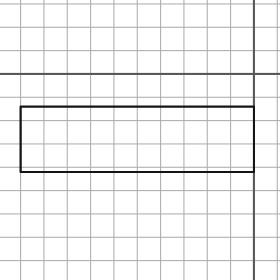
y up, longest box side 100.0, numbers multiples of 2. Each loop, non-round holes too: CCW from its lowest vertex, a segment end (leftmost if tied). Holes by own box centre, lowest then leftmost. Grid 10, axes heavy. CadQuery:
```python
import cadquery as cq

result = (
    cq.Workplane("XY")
    .moveTo(-100.0, -42.0)
    .lineTo(0.0, -42.0)
    .lineTo(0.0, -14.0)
    .lineTo(-100.0, -14.0)
    .close()
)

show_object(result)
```